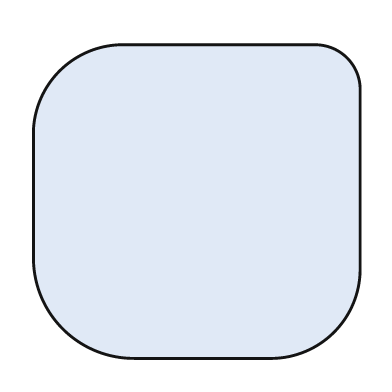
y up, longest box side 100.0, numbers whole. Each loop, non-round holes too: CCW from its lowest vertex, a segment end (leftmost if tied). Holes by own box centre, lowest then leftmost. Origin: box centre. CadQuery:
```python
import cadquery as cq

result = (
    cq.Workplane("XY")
    .moveTo(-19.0, -48.0)
    .lineTo(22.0, -48.0)
    .threePointArc((42.0, -40.0), (50.0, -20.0))
    .lineTo(50.0, 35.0)
    .threePointArc((46.0, 44.0), (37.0, 48.0))
    .lineTo(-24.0, 48.0)
    .threePointArc((-42.0, 40.0), (-50.0, 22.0))
    .lineTo(-50.0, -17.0)
    .threePointArc((-41.0, -39.0), (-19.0, -48.0))
    .close()
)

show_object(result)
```